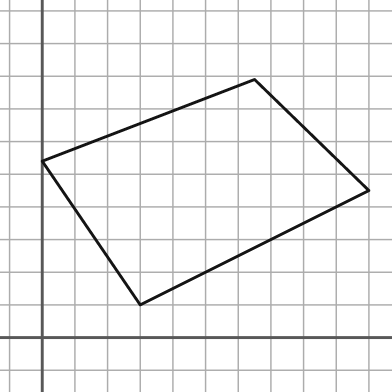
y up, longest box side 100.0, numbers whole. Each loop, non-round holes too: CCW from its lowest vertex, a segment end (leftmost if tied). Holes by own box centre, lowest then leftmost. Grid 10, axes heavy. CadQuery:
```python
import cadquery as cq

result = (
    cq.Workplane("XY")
    .moveTo(30.0, 10.0)
    .lineTo(100.0, 45.0)
    .lineTo(65.0, 79.0)
    .lineTo(0.0, 54.0)
    .close()
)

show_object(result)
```